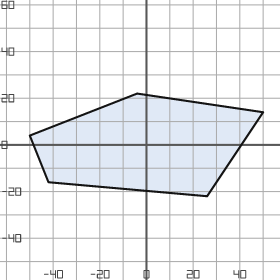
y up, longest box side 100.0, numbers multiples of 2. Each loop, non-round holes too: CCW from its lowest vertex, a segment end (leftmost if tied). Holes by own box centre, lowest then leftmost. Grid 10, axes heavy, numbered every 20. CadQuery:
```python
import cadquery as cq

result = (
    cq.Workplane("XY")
    .moveTo(26.0, -22.0)
    .lineTo(50.0, 14.0)
    .lineTo(-4.0, 22.0)
    .lineTo(-50.0, 4.0)
    .lineTo(-42.0, -16.0)
    .close()
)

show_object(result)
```